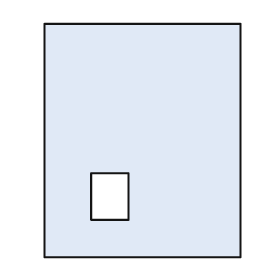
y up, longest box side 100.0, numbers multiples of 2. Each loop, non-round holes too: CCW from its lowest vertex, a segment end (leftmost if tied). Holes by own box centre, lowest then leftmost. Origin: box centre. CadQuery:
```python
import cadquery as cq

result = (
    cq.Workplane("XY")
    .moveTo(-42.0, -50.0)
    .lineTo(42.0, -50.0)
    .lineTo(42.0, 50.0)
    .lineTo(-42.0, 50.0)
    .close()
    .moveTo(-22.0, -34.0)
    .lineTo(-6.0, -34.0)
    .lineTo(-6.0, -14.0)
    .lineTo(-22.0, -14.0)
    .close()
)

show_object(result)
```